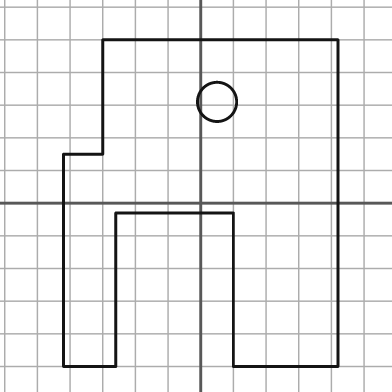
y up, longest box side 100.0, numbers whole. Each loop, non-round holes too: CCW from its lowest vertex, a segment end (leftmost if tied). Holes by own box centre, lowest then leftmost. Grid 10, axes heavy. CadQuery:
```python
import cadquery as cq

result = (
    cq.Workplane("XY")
    .moveTo(-42.0, -50.0)
    .lineTo(-26.0, -50.0)
    .lineTo(-26.0, -3.0)
    .lineTo(10.0, -3.0)
    .lineTo(10.0, -50.0)
    .lineTo(42.0, -50.0)
    .lineTo(42.0, 50.0)
    .lineTo(-30.0, 50.0)
    .lineTo(-30.0, 15.0)
    .lineTo(-42.0, 15.0)
    .close()
    .moveTo(5.0, 31.0)
    .circle(6.0)
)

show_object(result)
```